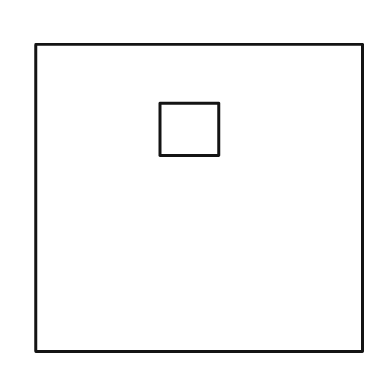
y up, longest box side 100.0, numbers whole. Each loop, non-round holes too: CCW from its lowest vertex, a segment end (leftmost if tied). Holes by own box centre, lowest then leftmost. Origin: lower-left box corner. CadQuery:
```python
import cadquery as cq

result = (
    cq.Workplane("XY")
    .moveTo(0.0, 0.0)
    .lineTo(100.0, 0.0)
    .lineTo(100.0, 94.0)
    .lineTo(0.0, 94.0)
    .close()
    .moveTo(38.0, 60.0)
    .lineTo(56.0, 60.0)
    .lineTo(56.0, 76.0)
    .lineTo(38.0, 76.0)
    .close()
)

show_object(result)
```